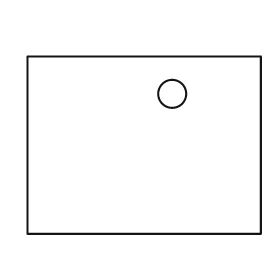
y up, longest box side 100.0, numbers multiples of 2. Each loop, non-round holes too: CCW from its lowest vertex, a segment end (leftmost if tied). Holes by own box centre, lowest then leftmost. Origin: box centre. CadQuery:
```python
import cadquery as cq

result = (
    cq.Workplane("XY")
    .moveTo(-50.0, -38.0)
    .lineTo(50.0, -38.0)
    .lineTo(50.0, 38.0)
    .lineTo(-50.0, 38.0)
    .close()
    .moveTo(12.0, 22.0)
    .circle(6.0)
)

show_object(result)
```